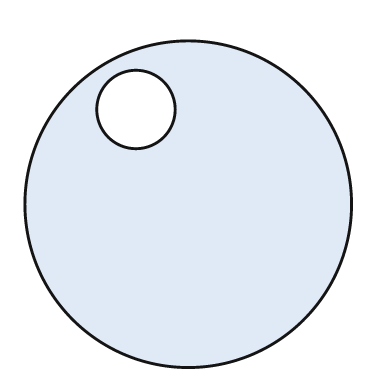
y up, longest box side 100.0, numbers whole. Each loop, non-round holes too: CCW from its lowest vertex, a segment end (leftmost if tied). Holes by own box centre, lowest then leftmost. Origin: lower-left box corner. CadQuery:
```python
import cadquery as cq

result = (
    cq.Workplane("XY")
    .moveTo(50.0, 50.0)
    .circle(50.0)
    .moveTo(34.0, 79.0)
    .circle(12.0)
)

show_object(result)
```